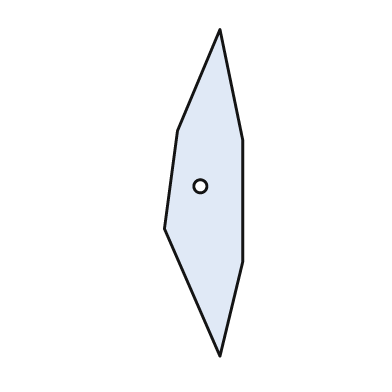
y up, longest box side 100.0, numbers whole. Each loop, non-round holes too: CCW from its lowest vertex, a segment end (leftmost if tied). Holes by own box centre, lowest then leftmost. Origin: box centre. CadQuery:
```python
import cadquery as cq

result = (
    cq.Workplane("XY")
    .moveTo(5.0, -50.0)
    .lineTo(12.0, -21.0)
    .lineTo(12.0, 16.0)
    .lineTo(5.0, 50.0)
    .lineTo(-8.0, 19.0)
    .lineTo(-12.0, -11.0)
    .close()
    .moveTo(-1.0, 2.0)
    .circle(2.0)
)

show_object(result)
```